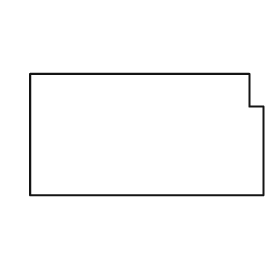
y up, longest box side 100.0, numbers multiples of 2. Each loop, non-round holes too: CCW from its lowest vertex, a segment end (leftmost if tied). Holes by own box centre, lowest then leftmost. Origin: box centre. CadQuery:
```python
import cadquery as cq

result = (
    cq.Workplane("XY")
    .moveTo(-50.0, -26.0)
    .lineTo(50.0, -26.0)
    .lineTo(50.0, 12.0)
    .lineTo(44.0, 12.0)
    .lineTo(44.0, 26.0)
    .lineTo(-50.0, 26.0)
    .close()
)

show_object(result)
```